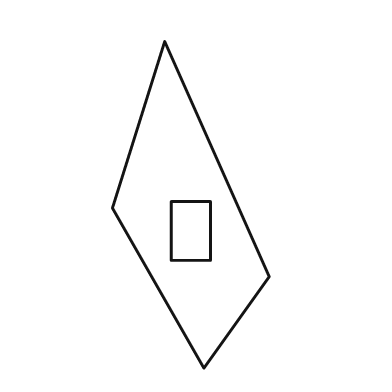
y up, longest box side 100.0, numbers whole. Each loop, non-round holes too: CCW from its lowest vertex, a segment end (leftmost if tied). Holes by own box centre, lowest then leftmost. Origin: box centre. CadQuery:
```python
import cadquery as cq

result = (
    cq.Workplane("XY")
    .moveTo(4.0, -50.0)
    .lineTo(24.0, -22.0)
    .lineTo(-8.0, 50.0)
    .lineTo(-24.0, -1.0)
    .close()
    .moveTo(-6.0, -17.0)
    .lineTo(6.0, -17.0)
    .lineTo(6.0, 1.0)
    .lineTo(-6.0, 1.0)
    .close()
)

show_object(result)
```